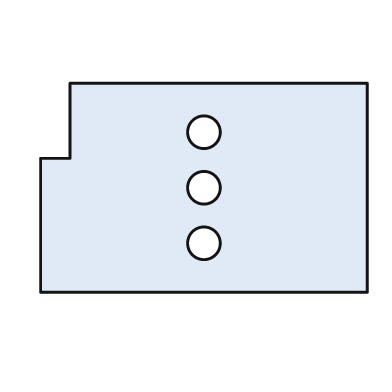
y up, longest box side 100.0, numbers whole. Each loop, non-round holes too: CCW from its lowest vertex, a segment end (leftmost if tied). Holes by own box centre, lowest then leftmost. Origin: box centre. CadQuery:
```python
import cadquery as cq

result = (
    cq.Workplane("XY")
    .moveTo(-50.0, -32.0)
    .lineTo(50.0, -32.0)
    .lineTo(50.0, 32.0)
    .lineTo(-41.0, 32.0)
    .lineTo(-41.0, 9.0)
    .lineTo(-50.0, 9.0)
    .close()
    .moveTo(0.0, -17.0)
    .circle(5.0)
    .moveTo(0.0, 0.0)
    .circle(5.0)
    .moveTo(0.0, 17.0)
    .circle(5.0)
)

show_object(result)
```